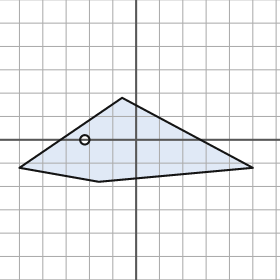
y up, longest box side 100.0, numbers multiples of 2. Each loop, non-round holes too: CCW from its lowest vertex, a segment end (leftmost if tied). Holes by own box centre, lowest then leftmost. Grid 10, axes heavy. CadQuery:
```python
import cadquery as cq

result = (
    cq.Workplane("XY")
    .moveTo(-16.0, -18.0)
    .lineTo(50.0, -12.0)
    .lineTo(-6.0, 18.0)
    .lineTo(-50.0, -12.0)
    .close()
    .moveTo(-22.0, 0.0)
    .circle(2.0)
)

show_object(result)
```